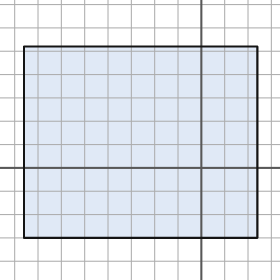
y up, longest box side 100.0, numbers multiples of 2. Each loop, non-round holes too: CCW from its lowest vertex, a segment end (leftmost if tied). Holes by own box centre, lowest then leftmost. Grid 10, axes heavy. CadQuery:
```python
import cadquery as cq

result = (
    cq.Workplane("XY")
    .moveTo(-76.0, -30.0)
    .lineTo(24.0, -30.0)
    .lineTo(24.0, 52.0)
    .lineTo(-76.0, 52.0)
    .close()
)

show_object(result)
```